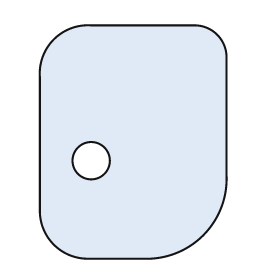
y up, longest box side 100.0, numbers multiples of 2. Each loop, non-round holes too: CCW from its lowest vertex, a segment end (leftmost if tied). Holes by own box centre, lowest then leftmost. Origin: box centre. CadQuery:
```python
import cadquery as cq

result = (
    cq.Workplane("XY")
    .moveTo(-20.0, -50.0)
    .lineTo(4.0, -50.0)
    .threePointArc((30.0, -40.0), (40.0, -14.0))
    .lineTo(40.0, 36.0)
    .threePointArc((36.0, 46.0), (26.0, 50.0))
    .lineTo(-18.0, 50.0)
    .threePointArc((-34.0, 44.0), (-40.0, 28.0))
    .lineTo(-40.0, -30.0)
    .threePointArc((-34.0, -44.0), (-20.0, -50.0))
    .close()
    .moveTo(-18.0, -8.0)
    .circle(8.0)
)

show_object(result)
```